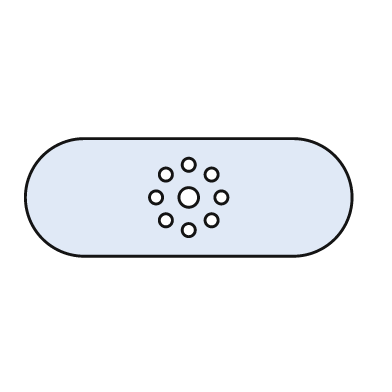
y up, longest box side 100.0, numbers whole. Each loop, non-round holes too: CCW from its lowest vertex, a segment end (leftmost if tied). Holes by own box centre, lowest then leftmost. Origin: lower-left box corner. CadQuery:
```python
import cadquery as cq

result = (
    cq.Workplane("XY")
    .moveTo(18.0, 0.0)
    .lineTo(82.0, 0.0)
    .threePointArc((100.0, 18.0), (82.0, 36.0))
    .lineTo(18.0, 36.0)
    .threePointArc((0.0, 18.0), (18.0, 0.0))
    .close()
    .moveTo(50.0, 8.0)
    .circle(2.0)
    .moveTo(43.0, 11.0)
    .circle(2.0)
    .moveTo(57.0, 11.0)
    .circle(2.0)
    .moveTo(40.0, 18.0)
    .circle(2.0)
    .moveTo(50.0, 18.0)
    .circle(3.0)
    .moveTo(60.0, 18.0)
    .circle(2.0)
    .moveTo(43.0, 25.0)
    .circle(2.0)
    .moveTo(57.0, 25.0)
    .circle(2.0)
    .moveTo(50.0, 28.0)
    .circle(2.0)
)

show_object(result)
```